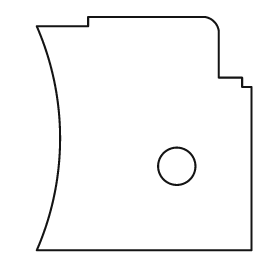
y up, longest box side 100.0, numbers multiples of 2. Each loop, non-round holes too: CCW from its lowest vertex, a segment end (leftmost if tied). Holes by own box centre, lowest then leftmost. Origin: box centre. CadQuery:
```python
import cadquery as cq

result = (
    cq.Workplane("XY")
    .moveTo(-46.0, -50.0)
    .lineTo(46.0, -50.0)
    .lineTo(46.0, 20.0)
    .lineTo(42.0, 20.0)
    .lineTo(42.0, 24.0)
    .lineTo(32.0, 24.0)
    .lineTo(32.0, 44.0)
    .threePointArc((30.0, 48.0), (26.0, 50.0))
    .lineTo(-24.0, 50.0)
    .lineTo(-24.0, 46.0)
    .lineTo(-46.0, 46.0)
    .threePointArc((-36.0, -2.0), (-46.0, -50.0))
    .close()
    .moveTo(14.0, -14.0)
    .circle(8.0)
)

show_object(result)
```